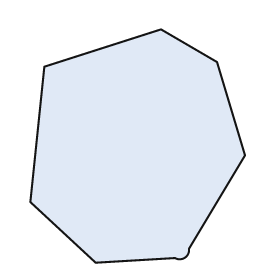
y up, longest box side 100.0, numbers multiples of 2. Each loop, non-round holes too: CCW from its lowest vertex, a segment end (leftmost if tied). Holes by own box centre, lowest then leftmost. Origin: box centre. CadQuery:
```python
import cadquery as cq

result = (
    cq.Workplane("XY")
    .moveTo(-18.0, -50.0)
    .lineTo(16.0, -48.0)
    .threePointArc((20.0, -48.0), (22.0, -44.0))
    .lineTo(46.0, -4.0)
    .lineTo(34.0, 36.0)
    .lineTo(10.0, 50.0)
    .lineTo(-40.0, 34.0)
    .lineTo(-46.0, -24.0)
    .close()
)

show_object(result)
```